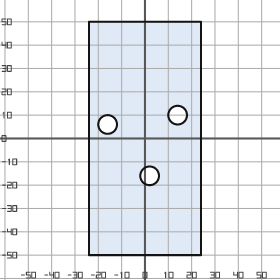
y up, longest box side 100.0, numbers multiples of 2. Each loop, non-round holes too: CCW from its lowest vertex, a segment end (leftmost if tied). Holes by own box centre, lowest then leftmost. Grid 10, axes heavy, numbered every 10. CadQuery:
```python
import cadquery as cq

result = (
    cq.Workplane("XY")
    .moveTo(-24.0, -50.0)
    .lineTo(24.0, -50.0)
    .lineTo(24.0, 50.0)
    .lineTo(-24.0, 50.0)
    .close()
    .moveTo(2.0, -16.0)
    .circle(4.0)
    .moveTo(-16.0, 6.0)
    .circle(4.0)
    .moveTo(14.0, 10.0)
    .circle(4.0)
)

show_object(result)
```